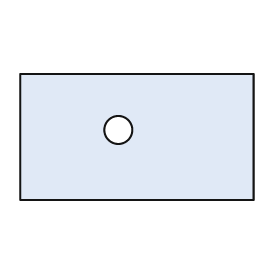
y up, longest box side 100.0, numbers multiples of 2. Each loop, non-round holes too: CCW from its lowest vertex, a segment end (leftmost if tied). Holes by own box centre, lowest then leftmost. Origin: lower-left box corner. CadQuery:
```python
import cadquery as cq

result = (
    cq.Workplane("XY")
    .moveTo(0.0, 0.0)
    .lineTo(100.0, 0.0)
    .lineTo(100.0, 54.0)
    .lineTo(0.0, 54.0)
    .close()
    .moveTo(42.0, 30.0)
    .circle(6.0)
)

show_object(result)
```